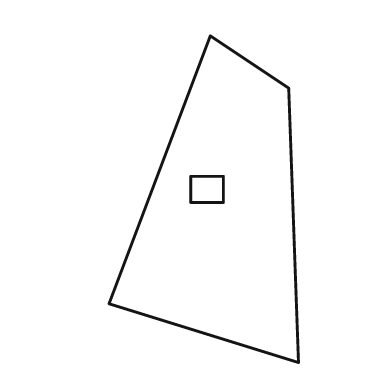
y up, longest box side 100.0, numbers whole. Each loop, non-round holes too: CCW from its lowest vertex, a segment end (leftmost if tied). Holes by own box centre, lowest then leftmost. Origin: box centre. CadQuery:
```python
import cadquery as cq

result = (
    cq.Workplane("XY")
    .moveTo(29.0, -50.0)
    .lineTo(26.0, 34.0)
    .lineTo(2.0, 50.0)
    .lineTo(-29.0, -32.0)
    .close()
    .moveTo(-4.0, -1.0)
    .lineTo(6.0, -1.0)
    .lineTo(6.0, 7.0)
    .lineTo(-4.0, 7.0)
    .close()
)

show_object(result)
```